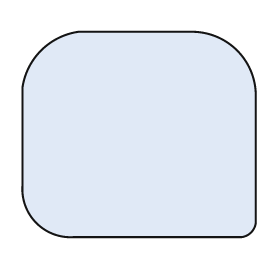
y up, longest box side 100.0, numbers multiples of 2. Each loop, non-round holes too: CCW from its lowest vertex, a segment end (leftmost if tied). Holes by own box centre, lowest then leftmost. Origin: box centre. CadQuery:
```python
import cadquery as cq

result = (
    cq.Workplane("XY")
    .moveTo(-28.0, -44.0)
    .lineTo(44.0, -44.0)
    .threePointArc((48.0, -42.0), (50.0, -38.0))
    .lineTo(50.0, 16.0)
    .threePointArc((42.0, 36.0), (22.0, 44.0))
    .lineTo(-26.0, 44.0)
    .threePointArc((-42.0, 36.0), (-50.0, 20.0))
    .lineTo(-50.0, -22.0)
    .threePointArc((-44.0, -38.0), (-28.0, -44.0))
    .close()
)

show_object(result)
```